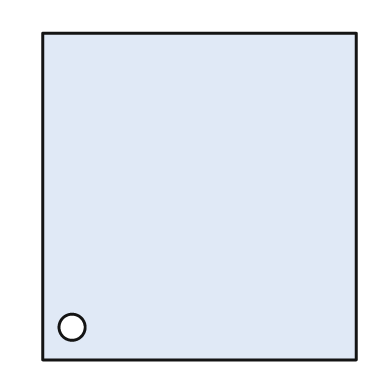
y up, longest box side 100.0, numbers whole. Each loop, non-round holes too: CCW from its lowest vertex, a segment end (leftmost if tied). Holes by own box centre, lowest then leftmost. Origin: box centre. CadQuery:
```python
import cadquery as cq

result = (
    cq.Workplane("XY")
    .moveTo(-48.0, -50.0)
    .lineTo(48.0, -50.0)
    .lineTo(48.0, 50.0)
    .lineTo(-48.0, 50.0)
    .close()
    .moveTo(-39.0, -40.0)
    .circle(4.0)
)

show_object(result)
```